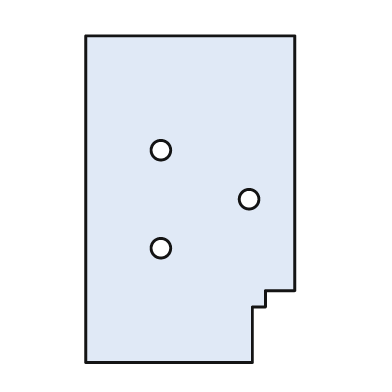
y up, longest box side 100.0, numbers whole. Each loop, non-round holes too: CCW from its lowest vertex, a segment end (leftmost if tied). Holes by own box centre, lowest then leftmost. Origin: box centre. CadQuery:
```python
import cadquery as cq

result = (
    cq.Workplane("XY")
    .moveTo(-32.0, -50.0)
    .lineTo(19.0, -50.0)
    .lineTo(19.0, -33.0)
    .lineTo(23.0, -33.0)
    .lineTo(23.0, -28.0)
    .lineTo(32.0, -28.0)
    .lineTo(32.0, 50.0)
    .lineTo(-32.0, 50.0)
    .close()
    .moveTo(-9.0, -15.0)
    .circle(3.0)
    .moveTo(18.0, 0.0)
    .circle(3.0)
    .moveTo(-9.0, 15.0)
    .circle(3.0)
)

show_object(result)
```